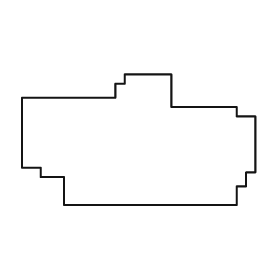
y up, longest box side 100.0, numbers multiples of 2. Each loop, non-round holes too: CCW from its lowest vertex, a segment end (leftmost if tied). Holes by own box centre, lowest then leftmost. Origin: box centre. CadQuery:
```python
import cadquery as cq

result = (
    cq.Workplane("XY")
    .moveTo(-32.0, -28.0)
    .lineTo(42.0, -28.0)
    .lineTo(42.0, -20.0)
    .lineTo(46.0, -20.0)
    .lineTo(46.0, -14.0)
    .lineTo(50.0, -14.0)
    .lineTo(50.0, 10.0)
    .lineTo(42.0, 10.0)
    .lineTo(42.0, 14.0)
    .lineTo(14.0, 14.0)
    .lineTo(14.0, 28.0)
    .lineTo(-6.0, 28.0)
    .lineTo(-6.0, 24.0)
    .lineTo(-10.0, 24.0)
    .lineTo(-10.0, 18.0)
    .lineTo(-50.0, 18.0)
    .lineTo(-50.0, -12.0)
    .lineTo(-42.0, -12.0)
    .lineTo(-42.0, -16.0)
    .lineTo(-32.0, -16.0)
    .close()
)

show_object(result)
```